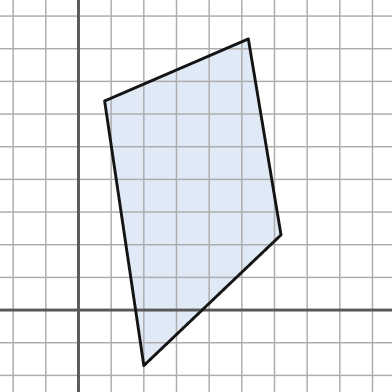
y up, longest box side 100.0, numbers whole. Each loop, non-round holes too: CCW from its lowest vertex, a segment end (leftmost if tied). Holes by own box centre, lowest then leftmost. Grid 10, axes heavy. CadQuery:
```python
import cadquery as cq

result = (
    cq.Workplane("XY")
    .moveTo(20.0, -17.0)
    .lineTo(62.0, 23.0)
    .lineTo(52.0, 83.0)
    .lineTo(8.0, 64.0)
    .close()
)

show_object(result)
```